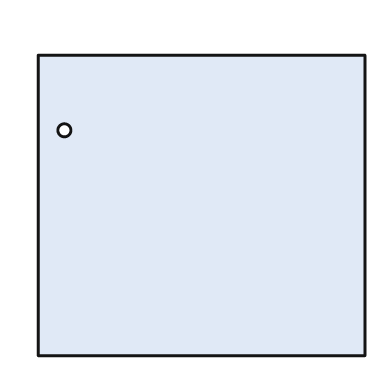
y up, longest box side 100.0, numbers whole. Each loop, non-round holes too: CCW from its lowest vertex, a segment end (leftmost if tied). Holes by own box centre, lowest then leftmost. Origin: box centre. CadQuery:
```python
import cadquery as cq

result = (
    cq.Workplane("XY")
    .moveTo(-50.0, -46.0)
    .lineTo(50.0, -46.0)
    .lineTo(50.0, 46.0)
    .lineTo(-50.0, 46.0)
    .close()
    .moveTo(-42.0, 23.0)
    .circle(2.0)
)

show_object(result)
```